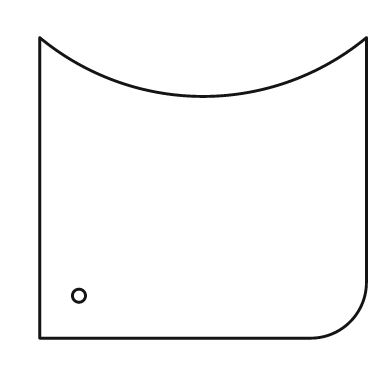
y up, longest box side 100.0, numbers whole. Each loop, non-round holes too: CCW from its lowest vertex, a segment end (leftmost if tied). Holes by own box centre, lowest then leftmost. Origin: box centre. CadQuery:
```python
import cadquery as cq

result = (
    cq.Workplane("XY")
    .moveTo(-50.0, -46.0)
    .lineTo(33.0, -46.0)
    .threePointArc((45.0, -41.0), (50.0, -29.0))
    .lineTo(50.0, 46.0)
    .threePointArc((0.0, 28.0), (-50.0, 46.0))
    .close()
    .moveTo(-38.0, -33.0)
    .circle(2.0)
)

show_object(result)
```